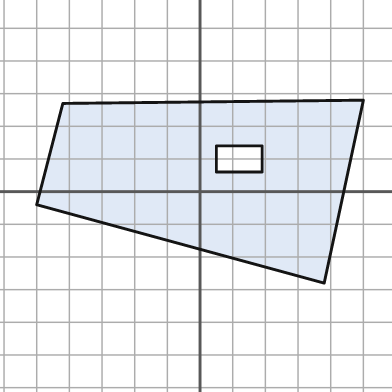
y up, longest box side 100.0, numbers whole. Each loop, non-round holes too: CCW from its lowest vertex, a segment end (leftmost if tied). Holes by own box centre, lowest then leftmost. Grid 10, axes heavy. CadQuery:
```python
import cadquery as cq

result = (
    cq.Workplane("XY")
    .moveTo(38.0, -28.0)
    .lineTo(50.0, 28.0)
    .lineTo(-42.0, 27.0)
    .lineTo(-50.0, -4.0)
    .close()
    .moveTo(5.0, 6.0)
    .lineTo(19.0, 6.0)
    .lineTo(19.0, 14.0)
    .lineTo(5.0, 14.0)
    .close()
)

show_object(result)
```